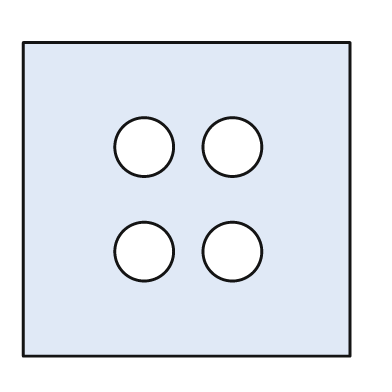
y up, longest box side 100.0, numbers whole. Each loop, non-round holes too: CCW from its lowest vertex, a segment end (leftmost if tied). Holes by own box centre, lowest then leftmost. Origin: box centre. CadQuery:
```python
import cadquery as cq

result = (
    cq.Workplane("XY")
    .moveTo(-50.0, -48.0)
    .lineTo(50.0, -48.0)
    .lineTo(50.0, 48.0)
    .lineTo(-50.0, 48.0)
    .close()
    .moveTo(-13.0, -16.0)
    .circle(9.0)
    .moveTo(14.0, -16.0)
    .circle(9.0)
    .moveTo(-13.0, 16.0)
    .circle(9.0)
    .moveTo(14.0, 16.0)
    .circle(9.0)
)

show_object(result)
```